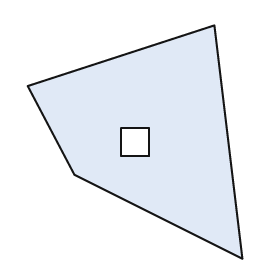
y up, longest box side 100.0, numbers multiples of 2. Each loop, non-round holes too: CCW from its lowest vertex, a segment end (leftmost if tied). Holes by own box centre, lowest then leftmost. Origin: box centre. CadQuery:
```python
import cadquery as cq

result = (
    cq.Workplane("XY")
    .moveTo(46.0, -50.0)
    .lineTo(34.0, 50.0)
    .lineTo(-46.0, 24.0)
    .lineTo(-26.0, -14.0)
    .close()
    .moveTo(-6.0, -6.0)
    .lineTo(6.0, -6.0)
    .lineTo(6.0, 6.0)
    .lineTo(-6.0, 6.0)
    .close()
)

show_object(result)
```